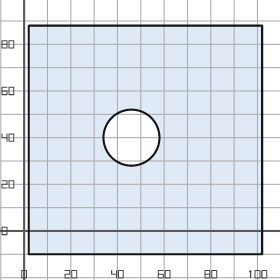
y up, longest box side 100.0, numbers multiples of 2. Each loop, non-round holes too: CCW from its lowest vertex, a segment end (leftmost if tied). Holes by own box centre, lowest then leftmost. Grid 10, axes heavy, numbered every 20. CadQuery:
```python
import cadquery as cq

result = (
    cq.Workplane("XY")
    .moveTo(2.0, -10.0)
    .lineTo(102.0, -10.0)
    .lineTo(102.0, 88.0)
    .lineTo(2.0, 88.0)
    .close()
    .moveTo(46.0, 40.0)
    .circle(12.0)
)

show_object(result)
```